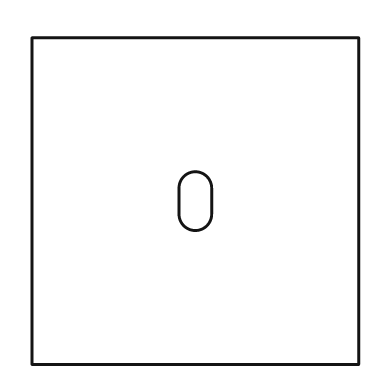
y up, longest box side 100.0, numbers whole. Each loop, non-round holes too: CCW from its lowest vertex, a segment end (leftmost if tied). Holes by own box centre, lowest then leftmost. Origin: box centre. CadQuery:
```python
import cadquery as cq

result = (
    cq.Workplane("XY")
    .moveTo(-50.0, -50.0)
    .lineTo(50.0, -50.0)
    .lineTo(50.0, 50.0)
    .lineTo(-50.0, 50.0)
    .close()
    .moveTo(-5.0, -4.0)
    .threePointArc((0.0, -9.0), (5.0, -4.0))
    .lineTo(5.0, 4.0)
    .threePointArc((0.0, 9.0), (-5.0, 4.0))
    .close()
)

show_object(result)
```